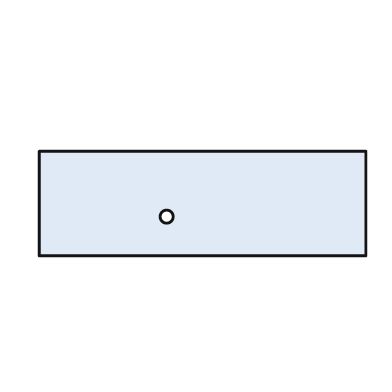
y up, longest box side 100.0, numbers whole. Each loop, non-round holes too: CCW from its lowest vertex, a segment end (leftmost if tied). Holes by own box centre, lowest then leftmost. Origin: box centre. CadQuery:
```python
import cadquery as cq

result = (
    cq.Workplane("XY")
    .moveTo(-50.0, -16.0)
    .lineTo(50.0, -16.0)
    .lineTo(50.0, 16.0)
    .lineTo(-50.0, 16.0)
    .close()
    .moveTo(-11.0, -4.0)
    .circle(2.0)
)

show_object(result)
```